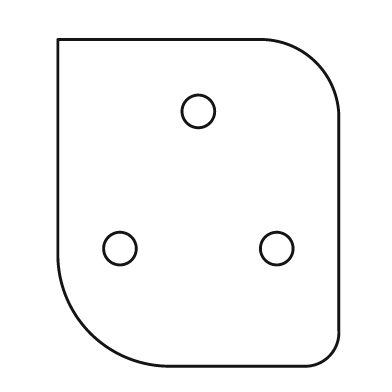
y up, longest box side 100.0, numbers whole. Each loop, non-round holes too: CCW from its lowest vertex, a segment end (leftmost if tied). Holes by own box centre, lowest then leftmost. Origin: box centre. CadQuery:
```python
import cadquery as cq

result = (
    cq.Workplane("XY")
    .moveTo(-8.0, -50.0)
    .lineTo(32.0, -50.0)
    .threePointArc((40.0, -47.0), (43.0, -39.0))
    .lineTo(43.0, 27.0)
    .threePointArc((36.0, 43.0), (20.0, 50.0))
    .lineTo(-43.0, 50.0)
    .lineTo(-43.0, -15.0)
    .threePointArc((-33.0, -40.0), (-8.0, -50.0))
    .close()
    .moveTo(-24.0, -14.0)
    .circle(5.0)
    .moveTo(24.0, -14.0)
    .circle(5.0)
    .moveTo(0.0, 28.0)
    .circle(5.0)
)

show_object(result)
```